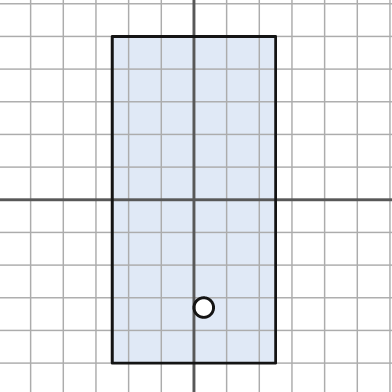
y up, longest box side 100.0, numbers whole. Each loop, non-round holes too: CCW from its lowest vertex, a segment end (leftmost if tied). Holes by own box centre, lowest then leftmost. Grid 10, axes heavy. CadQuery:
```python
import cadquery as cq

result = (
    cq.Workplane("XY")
    .moveTo(-25.0, -50.0)
    .lineTo(25.0, -50.0)
    .lineTo(25.0, 50.0)
    .lineTo(-25.0, 50.0)
    .close()
    .moveTo(3.0, -33.0)
    .circle(3.0)
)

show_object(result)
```